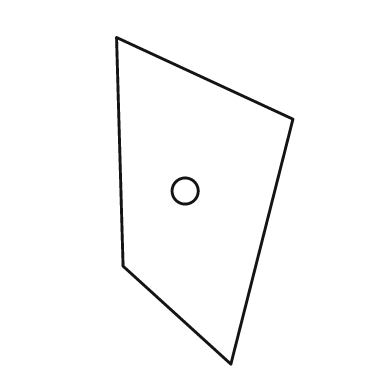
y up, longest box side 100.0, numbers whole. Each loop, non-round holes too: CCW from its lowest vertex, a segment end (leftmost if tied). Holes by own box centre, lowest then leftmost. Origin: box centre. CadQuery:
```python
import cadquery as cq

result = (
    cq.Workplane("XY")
    .moveTo(8.0, -50.0)
    .lineTo(27.0, 25.0)
    .lineTo(-27.0, 50.0)
    .lineTo(-25.0, -20.0)
    .close()
    .moveTo(-6.0, 3.0)
    .circle(4.0)
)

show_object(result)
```